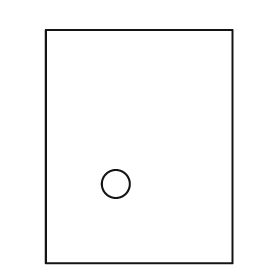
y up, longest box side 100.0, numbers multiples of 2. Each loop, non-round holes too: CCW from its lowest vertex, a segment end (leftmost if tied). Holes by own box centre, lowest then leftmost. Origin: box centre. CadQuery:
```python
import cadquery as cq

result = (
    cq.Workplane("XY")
    .moveTo(-40.0, -50.0)
    .lineTo(40.0, -50.0)
    .lineTo(40.0, 50.0)
    .lineTo(-40.0, 50.0)
    .close()
    .moveTo(-10.0, -16.0)
    .circle(6.0)
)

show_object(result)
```